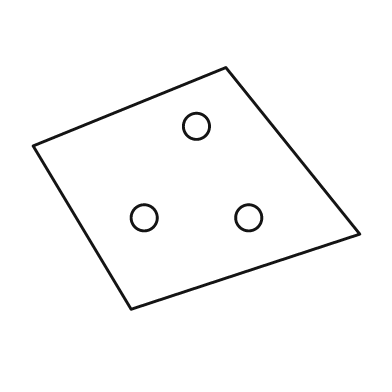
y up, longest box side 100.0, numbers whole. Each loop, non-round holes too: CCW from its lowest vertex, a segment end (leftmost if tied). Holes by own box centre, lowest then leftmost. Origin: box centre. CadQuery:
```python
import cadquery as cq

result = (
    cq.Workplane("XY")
    .moveTo(-20.0, -37.0)
    .lineTo(50.0, -14.0)
    .lineTo(9.0, 37.0)
    .lineTo(-50.0, 13.0)
    .close()
    .moveTo(-16.0, -9.0)
    .circle(4.0)
    .moveTo(16.0, -9.0)
    .circle(4.0)
    .moveTo(0.0, 19.0)
    .circle(4.0)
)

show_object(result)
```